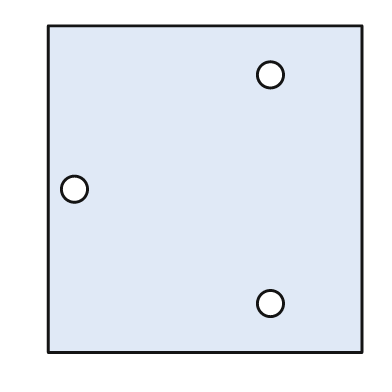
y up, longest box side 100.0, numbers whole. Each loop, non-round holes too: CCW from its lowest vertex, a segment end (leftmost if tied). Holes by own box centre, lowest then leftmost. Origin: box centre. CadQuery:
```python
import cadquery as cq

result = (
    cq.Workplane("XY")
    .moveTo(-48.0, -50.0)
    .lineTo(48.0, -50.0)
    .lineTo(48.0, 50.0)
    .lineTo(-48.0, 50.0)
    .close()
    .moveTo(20.0, -35.0)
    .circle(4.0)
    .moveTo(-40.0, 0.0)
    .circle(4.0)
    .moveTo(20.0, 35.0)
    .circle(4.0)
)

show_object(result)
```